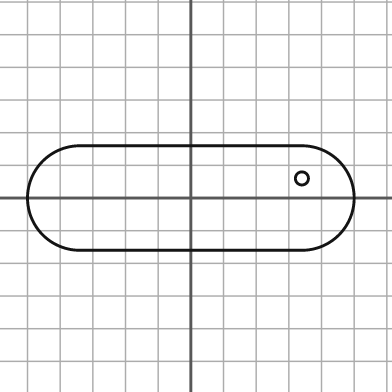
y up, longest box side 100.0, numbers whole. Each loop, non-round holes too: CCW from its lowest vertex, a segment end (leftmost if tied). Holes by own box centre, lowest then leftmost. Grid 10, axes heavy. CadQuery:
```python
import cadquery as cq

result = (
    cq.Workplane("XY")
    .moveTo(-34.0, -16.0)
    .lineTo(34.0, -16.0)
    .threePointArc((50.0, 0.0), (34.0, 16.0))
    .lineTo(-34.0, 16.0)
    .threePointArc((-50.0, 0.0), (-34.0, -16.0))
    .close()
    .moveTo(34.0, 6.0)
    .circle(2.0)
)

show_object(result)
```